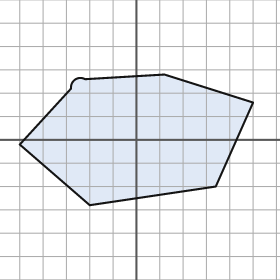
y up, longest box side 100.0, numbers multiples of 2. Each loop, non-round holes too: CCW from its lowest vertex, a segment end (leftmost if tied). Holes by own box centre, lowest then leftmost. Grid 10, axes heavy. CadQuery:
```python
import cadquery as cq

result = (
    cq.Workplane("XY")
    .moveTo(-20.0, -28.0)
    .lineTo(34.0, -20.0)
    .lineTo(50.0, 16.0)
    .lineTo(12.0, 28.0)
    .lineTo(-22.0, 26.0)
    .threePointArc((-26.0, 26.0), (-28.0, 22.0))
    .lineTo(-50.0, -2.0)
    .close()
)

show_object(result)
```